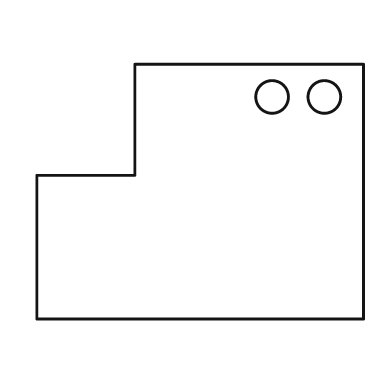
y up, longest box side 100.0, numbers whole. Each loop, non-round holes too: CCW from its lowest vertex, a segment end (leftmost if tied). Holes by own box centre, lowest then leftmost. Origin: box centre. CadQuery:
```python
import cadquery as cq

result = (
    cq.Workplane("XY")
    .moveTo(-50.0, -39.0)
    .lineTo(50.0, -39.0)
    .lineTo(50.0, 39.0)
    .lineTo(-20.0, 39.0)
    .lineTo(-20.0, 5.0)
    .lineTo(-50.0, 5.0)
    .close()
    .moveTo(22.0, 29.0)
    .circle(5.0)
    .moveTo(38.0, 29.0)
    .circle(5.0)
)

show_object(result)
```